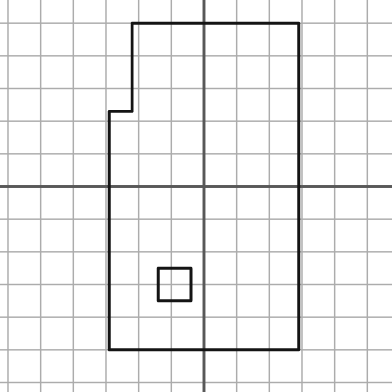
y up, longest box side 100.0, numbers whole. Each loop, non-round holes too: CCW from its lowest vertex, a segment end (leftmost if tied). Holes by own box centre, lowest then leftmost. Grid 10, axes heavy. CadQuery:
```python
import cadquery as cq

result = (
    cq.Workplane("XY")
    .moveTo(-29.0, -50.0)
    .lineTo(29.0, -50.0)
    .lineTo(29.0, 50.0)
    .lineTo(-22.0, 50.0)
    .lineTo(-22.0, 23.0)
    .lineTo(-29.0, 23.0)
    .close()
    .moveTo(-14.0, -35.0)
    .lineTo(-4.0, -35.0)
    .lineTo(-4.0, -25.0)
    .lineTo(-14.0, -25.0)
    .close()
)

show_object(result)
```